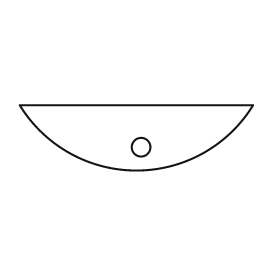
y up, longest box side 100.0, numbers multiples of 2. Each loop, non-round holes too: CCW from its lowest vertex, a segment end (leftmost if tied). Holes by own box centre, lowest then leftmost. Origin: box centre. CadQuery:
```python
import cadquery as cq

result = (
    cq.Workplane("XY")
    .moveTo(-50.0, 14.0)
    .threePointArc((0.0, -14.0), (50.0, 14.0))
    .close()
    .moveTo(2.0, -4.0)
    .circle(4.0)
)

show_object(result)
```